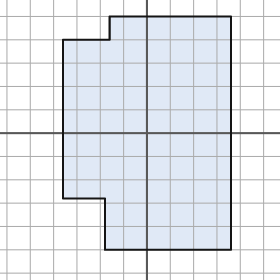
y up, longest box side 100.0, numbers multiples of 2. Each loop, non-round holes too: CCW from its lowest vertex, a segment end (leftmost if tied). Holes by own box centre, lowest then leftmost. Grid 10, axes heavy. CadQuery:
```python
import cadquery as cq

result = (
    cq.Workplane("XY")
    .moveTo(-18.0, -50.0)
    .lineTo(36.0, -50.0)
    .lineTo(36.0, 50.0)
    .lineTo(-16.0, 50.0)
    .lineTo(-16.0, 40.0)
    .lineTo(-36.0, 40.0)
    .lineTo(-36.0, -28.0)
    .lineTo(-18.0, -28.0)
    .close()
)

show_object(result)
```